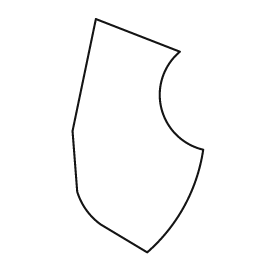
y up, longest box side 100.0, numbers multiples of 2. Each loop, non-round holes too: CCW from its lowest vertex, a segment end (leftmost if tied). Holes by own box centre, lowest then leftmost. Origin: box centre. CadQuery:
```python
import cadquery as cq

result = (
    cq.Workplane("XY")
    .moveTo(4.0, -50.0)
    .threePointArc((20.0, -30.0), (28.0, -6.0))
    .threePointArc((10.0, 12.0), (18.0, 36.0))
    .lineTo(-18.0, 50.0)
    .lineTo(-28.0, 2.0)
    .lineTo(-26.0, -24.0)
    .threePointArc((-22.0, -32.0), (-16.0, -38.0))
    .close()
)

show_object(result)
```